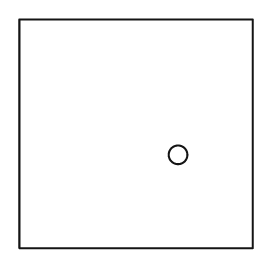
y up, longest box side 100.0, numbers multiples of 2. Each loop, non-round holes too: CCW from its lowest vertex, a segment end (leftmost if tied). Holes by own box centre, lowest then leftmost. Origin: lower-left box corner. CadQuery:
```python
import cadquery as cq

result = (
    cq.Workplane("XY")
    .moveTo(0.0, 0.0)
    .lineTo(100.0, 0.0)
    .lineTo(100.0, 98.0)
    .lineTo(0.0, 98.0)
    .close()
    .moveTo(68.0, 40.0)
    .circle(4.0)
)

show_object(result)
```